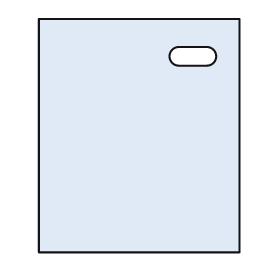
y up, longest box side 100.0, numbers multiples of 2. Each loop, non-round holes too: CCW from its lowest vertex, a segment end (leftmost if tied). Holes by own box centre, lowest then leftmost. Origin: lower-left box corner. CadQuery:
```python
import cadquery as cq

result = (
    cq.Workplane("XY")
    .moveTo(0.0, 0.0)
    .lineTo(86.0, 0.0)
    .lineTo(86.0, 100.0)
    .lineTo(0.0, 100.0)
    .close()
    .moveTo(60.0, 80.0)
    .lineTo(72.0, 80.0)
    .threePointArc((76.0, 84.0), (72.0, 88.0))
    .lineTo(60.0, 88.0)
    .threePointArc((56.0, 84.0), (60.0, 80.0))
    .close()
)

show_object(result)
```